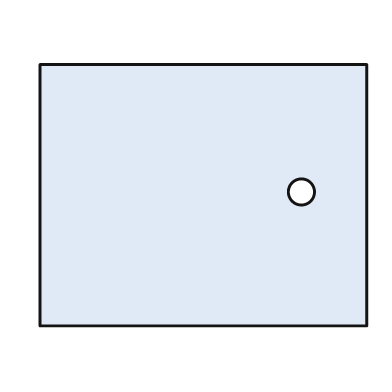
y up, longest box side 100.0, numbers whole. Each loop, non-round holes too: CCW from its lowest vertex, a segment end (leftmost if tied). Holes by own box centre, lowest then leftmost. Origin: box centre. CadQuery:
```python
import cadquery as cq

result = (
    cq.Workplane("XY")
    .moveTo(-50.0, -40.0)
    .lineTo(50.0, -40.0)
    .lineTo(50.0, 40.0)
    .lineTo(-50.0, 40.0)
    .close()
    .moveTo(30.0, 1.0)
    .circle(4.0)
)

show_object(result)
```